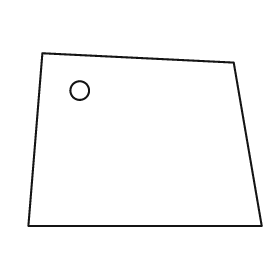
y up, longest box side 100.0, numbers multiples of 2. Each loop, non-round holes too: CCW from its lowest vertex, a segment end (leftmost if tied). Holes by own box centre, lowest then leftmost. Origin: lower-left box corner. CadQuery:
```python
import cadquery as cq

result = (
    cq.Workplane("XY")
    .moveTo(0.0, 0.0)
    .lineTo(100.0, 0.0)
    .lineTo(88.0, 70.0)
    .lineTo(6.0, 74.0)
    .close()
    .moveTo(22.0, 58.0)
    .circle(4.0)
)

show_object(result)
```